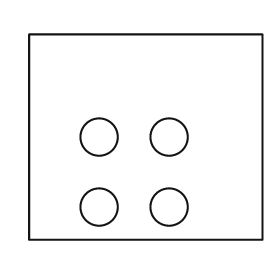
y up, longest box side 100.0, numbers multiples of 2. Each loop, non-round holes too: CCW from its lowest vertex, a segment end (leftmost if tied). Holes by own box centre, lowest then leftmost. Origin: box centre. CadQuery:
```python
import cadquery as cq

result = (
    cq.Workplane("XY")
    .moveTo(-50.0, -44.0)
    .lineTo(50.0, -44.0)
    .lineTo(50.0, 44.0)
    .lineTo(-50.0, 44.0)
    .close()
    .moveTo(-20.0, -30.0)
    .circle(8.0)
    .moveTo(10.0, -30.0)
    .circle(8.0)
    .moveTo(-20.0, 0.0)
    .circle(8.0)
    .moveTo(10.0, 0.0)
    .circle(8.0)
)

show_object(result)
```